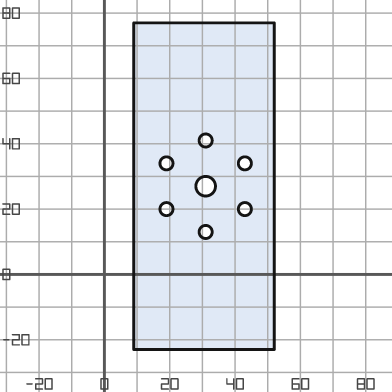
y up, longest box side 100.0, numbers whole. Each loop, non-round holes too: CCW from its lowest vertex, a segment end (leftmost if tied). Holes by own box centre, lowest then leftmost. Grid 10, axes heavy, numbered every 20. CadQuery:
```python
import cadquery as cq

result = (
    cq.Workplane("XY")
    .moveTo(9.0, -23.0)
    .lineTo(52.0, -23.0)
    .lineTo(52.0, 77.0)
    .lineTo(9.0, 77.0)
    .close()
    .moveTo(31.0, 13.0)
    .circle(2.0)
    .moveTo(19.0, 20.0)
    .circle(2.0)
    .moveTo(43.0, 20.0)
    .circle(2.0)
    .moveTo(31.0, 27.0)
    .circle(3.0)
    .moveTo(19.0, 34.0)
    .circle(2.0)
    .moveTo(43.0, 34.0)
    .circle(2.0)
    .moveTo(31.0, 41.0)
    .circle(2.0)
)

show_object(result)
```